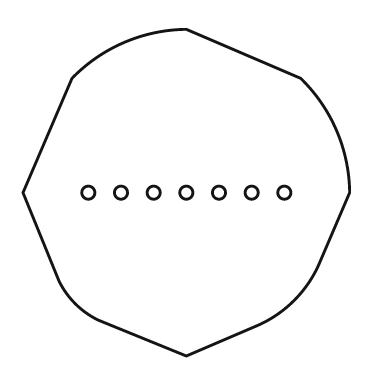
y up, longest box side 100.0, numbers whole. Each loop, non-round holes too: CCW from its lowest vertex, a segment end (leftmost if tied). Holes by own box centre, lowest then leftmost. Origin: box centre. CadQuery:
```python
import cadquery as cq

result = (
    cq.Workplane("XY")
    .moveTo(0.0, -50.0)
    .lineTo(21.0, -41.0)
    .threePointArc((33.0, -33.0), (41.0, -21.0))
    .lineTo(50.0, 0.0)
    .threePointArc((46.0, 19.0), (35.0, 35.0))
    .lineTo(0.0, 50.0)
    .threePointArc((-19.0, 46.0), (-35.0, 35.0))
    .lineTo(-50.0, 0.0)
    .lineTo(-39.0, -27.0)
    .threePointArc((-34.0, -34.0), (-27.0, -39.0))
    .close()
    .moveTo(-30.0, 0.0)
    .circle(2.0)
    .moveTo(-20.0, 0.0)
    .circle(2.0)
    .moveTo(-10.0, 0.0)
    .circle(2.0)
    .moveTo(0.0, 0.0)
    .circle(2.0)
    .moveTo(10.0, 0.0)
    .circle(2.0)
    .moveTo(20.0, 0.0)
    .circle(2.0)
    .moveTo(30.0, 0.0)
    .circle(2.0)
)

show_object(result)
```